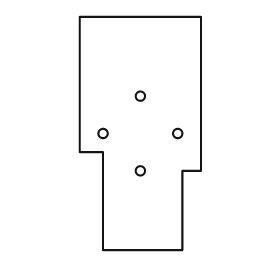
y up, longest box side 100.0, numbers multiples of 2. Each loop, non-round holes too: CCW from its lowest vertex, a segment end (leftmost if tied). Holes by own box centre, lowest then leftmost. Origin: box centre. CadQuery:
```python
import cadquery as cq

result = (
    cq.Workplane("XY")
    .moveTo(-16.0, -50.0)
    .lineTo(18.0, -50.0)
    .lineTo(18.0, -16.0)
    .lineTo(26.0, -16.0)
    .lineTo(26.0, 50.0)
    .lineTo(-26.0, 50.0)
    .lineTo(-26.0, -8.0)
    .lineTo(-16.0, -8.0)
    .close()
    .moveTo(0.0, -16.0)
    .circle(2.0)
    .moveTo(-16.0, 0.0)
    .circle(2.0)
    .moveTo(16.0, 0.0)
    .circle(2.0)
    .moveTo(0.0, 16.0)
    .circle(2.0)
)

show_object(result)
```